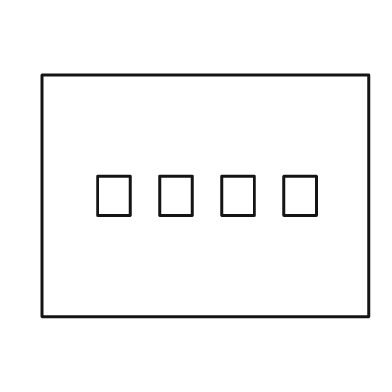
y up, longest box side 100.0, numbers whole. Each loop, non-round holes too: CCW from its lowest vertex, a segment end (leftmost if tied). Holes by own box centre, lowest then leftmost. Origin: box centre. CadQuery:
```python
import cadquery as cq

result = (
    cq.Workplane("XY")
    .moveTo(-50.0, -37.0)
    .lineTo(50.0, -37.0)
    .lineTo(50.0, 37.0)
    .lineTo(-50.0, 37.0)
    .close()
    .moveTo(-33.0, -6.0)
    .lineTo(-23.0, -6.0)
    .lineTo(-23.0, 6.0)
    .lineTo(-33.0, 6.0)
    .close()
    .moveTo(-14.0, -6.0)
    .lineTo(-4.0, -6.0)
    .lineTo(-4.0, 6.0)
    .lineTo(-14.0, 6.0)
    .close()
    .moveTo(5.0, -6.0)
    .lineTo(15.0, -6.0)
    .lineTo(15.0, 6.0)
    .lineTo(5.0, 6.0)
    .close()
    .moveTo(24.0, -6.0)
    .lineTo(34.0, -6.0)
    .lineTo(34.0, 6.0)
    .lineTo(24.0, 6.0)
    .close()
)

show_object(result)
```